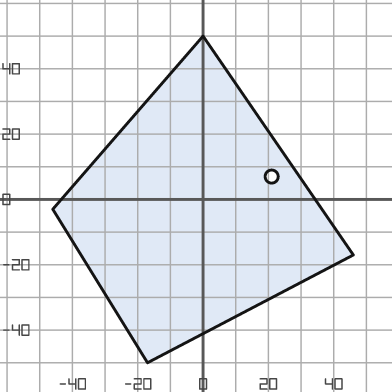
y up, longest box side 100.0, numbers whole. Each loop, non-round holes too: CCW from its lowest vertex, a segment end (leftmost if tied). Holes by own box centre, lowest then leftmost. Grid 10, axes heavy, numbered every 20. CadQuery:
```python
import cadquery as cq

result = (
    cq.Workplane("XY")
    .moveTo(-17.0, -50.0)
    .lineTo(46.0, -17.0)
    .lineTo(0.0, 50.0)
    .lineTo(-46.0, -3.0)
    .close()
    .moveTo(21.0, 7.0)
    .circle(2.0)
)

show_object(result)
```